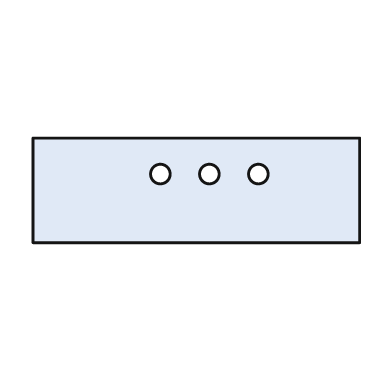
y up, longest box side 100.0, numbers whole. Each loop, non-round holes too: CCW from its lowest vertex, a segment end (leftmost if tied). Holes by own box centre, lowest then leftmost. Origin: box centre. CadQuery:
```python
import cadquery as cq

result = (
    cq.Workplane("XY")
    .moveTo(-50.0, -16.0)
    .lineTo(50.0, -16.0)
    .lineTo(50.0, 16.0)
    .lineTo(-50.0, 16.0)
    .close()
    .moveTo(-11.0, 5.0)
    .circle(3.0)
    .moveTo(4.0, 5.0)
    .circle(3.0)
    .moveTo(19.0, 5.0)
    .circle(3.0)
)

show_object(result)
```